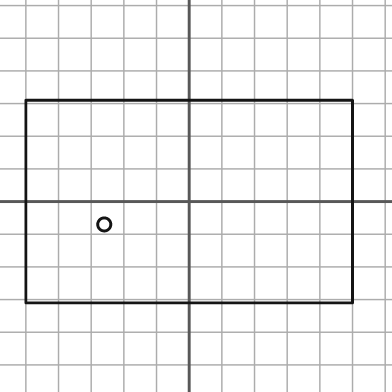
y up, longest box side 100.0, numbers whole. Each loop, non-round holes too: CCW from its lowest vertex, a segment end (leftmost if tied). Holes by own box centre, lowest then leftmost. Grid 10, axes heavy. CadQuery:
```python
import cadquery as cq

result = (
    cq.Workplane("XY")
    .moveTo(-50.0, -31.0)
    .lineTo(50.0, -31.0)
    .lineTo(50.0, 31.0)
    .lineTo(-50.0, 31.0)
    .close()
    .moveTo(-26.0, -7.0)
    .circle(2.0)
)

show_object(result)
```